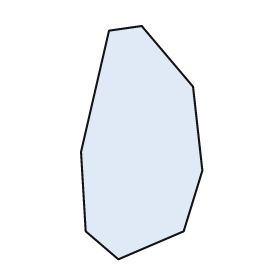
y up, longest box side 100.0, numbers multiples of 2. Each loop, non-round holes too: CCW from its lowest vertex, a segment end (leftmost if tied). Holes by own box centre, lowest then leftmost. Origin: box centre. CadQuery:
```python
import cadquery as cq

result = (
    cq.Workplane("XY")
    .moveTo(-10.0, -50.0)
    .lineTo(18.0, -38.0)
    .lineTo(26.0, -12.0)
    .lineTo(22.0, 24.0)
    .lineTo(0.0, 50.0)
    .lineTo(-14.0, 48.0)
    .lineTo(-26.0, -4.0)
    .lineTo(-24.0, -38.0)
    .close()
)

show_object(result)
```